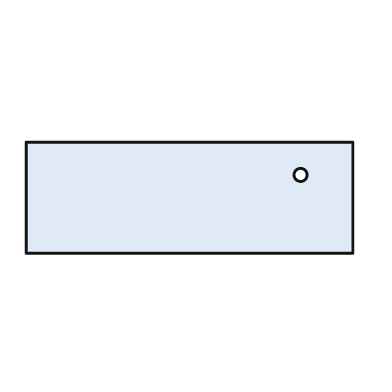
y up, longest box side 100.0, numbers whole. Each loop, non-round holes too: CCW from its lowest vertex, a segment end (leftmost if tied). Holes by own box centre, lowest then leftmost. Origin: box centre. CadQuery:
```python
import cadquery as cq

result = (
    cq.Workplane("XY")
    .moveTo(-50.0, -17.0)
    .lineTo(50.0, -17.0)
    .lineTo(50.0, 17.0)
    .lineTo(-50.0, 17.0)
    .close()
    .moveTo(34.0, 7.0)
    .circle(2.0)
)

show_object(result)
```